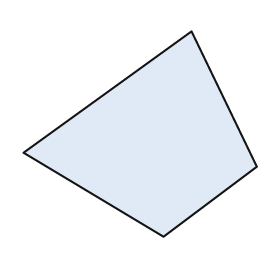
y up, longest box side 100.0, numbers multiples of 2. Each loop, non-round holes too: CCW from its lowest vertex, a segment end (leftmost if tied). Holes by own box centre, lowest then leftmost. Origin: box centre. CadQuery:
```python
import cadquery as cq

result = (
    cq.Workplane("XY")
    .moveTo(10.0, -44.0)
    .lineTo(50.0, -14.0)
    .lineTo(22.0, 44.0)
    .lineTo(-50.0, -8.0)
    .close()
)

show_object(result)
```